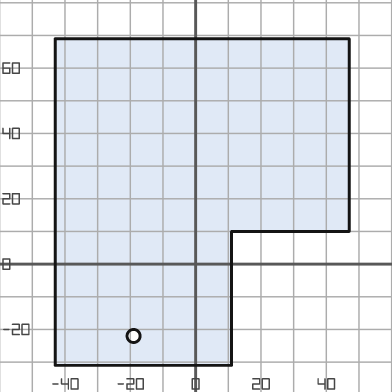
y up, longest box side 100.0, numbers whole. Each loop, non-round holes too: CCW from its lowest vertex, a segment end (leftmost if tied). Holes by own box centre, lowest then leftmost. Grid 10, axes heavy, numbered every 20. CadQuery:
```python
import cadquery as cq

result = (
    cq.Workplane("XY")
    .moveTo(-43.0, -31.0)
    .lineTo(11.0, -31.0)
    .lineTo(11.0, 10.0)
    .lineTo(47.0, 10.0)
    .lineTo(47.0, 69.0)
    .lineTo(-43.0, 69.0)
    .close()
    .moveTo(-19.0, -22.0)
    .circle(2.0)
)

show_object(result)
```